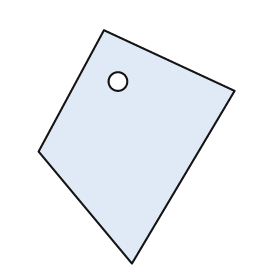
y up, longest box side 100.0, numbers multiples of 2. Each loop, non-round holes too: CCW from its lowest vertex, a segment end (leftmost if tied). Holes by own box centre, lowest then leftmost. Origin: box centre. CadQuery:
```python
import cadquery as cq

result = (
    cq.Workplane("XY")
    .moveTo(-2.0, -50.0)
    .lineTo(42.0, 24.0)
    .lineTo(-14.0, 50.0)
    .lineTo(-42.0, -2.0)
    .close()
    .moveTo(-8.0, 28.0)
    .circle(4.0)
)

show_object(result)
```